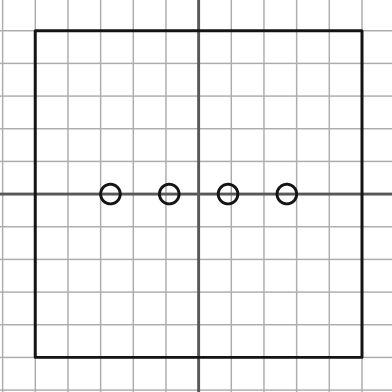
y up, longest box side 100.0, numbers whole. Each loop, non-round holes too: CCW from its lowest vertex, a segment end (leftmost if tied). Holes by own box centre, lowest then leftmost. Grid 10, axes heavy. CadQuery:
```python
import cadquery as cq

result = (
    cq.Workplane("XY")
    .moveTo(-50.0, -50.0)
    .lineTo(50.0, -50.0)
    .lineTo(50.0, 50.0)
    .lineTo(-50.0, 50.0)
    .close()
    .moveTo(-27.0, 0.0)
    .circle(3.0)
    .moveTo(-9.0, 0.0)
    .circle(3.0)
    .moveTo(9.0, 0.0)
    .circle(3.0)
    .moveTo(27.0, 0.0)
    .circle(3.0)
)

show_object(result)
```